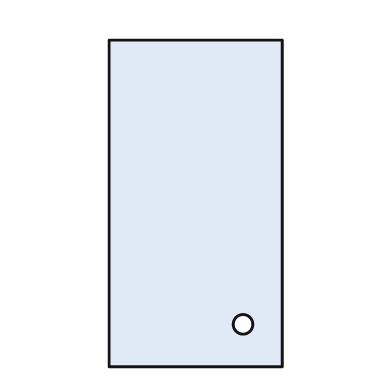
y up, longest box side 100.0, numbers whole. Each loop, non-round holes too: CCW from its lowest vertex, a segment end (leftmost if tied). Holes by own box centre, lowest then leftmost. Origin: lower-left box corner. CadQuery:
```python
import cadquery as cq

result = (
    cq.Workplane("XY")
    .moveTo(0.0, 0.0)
    .lineTo(53.0, 0.0)
    .lineTo(53.0, 100.0)
    .lineTo(0.0, 100.0)
    .close()
    .moveTo(41.0, 13.0)
    .circle(3.0)
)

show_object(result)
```